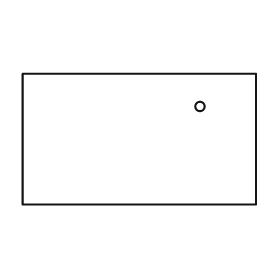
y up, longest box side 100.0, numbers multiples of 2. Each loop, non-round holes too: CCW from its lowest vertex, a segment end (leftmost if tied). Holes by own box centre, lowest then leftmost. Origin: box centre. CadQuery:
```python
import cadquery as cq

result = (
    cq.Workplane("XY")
    .moveTo(-50.0, -28.0)
    .lineTo(50.0, -28.0)
    .lineTo(50.0, 28.0)
    .lineTo(-50.0, 28.0)
    .close()
    .moveTo(26.0, 14.0)
    .circle(2.0)
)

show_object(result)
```